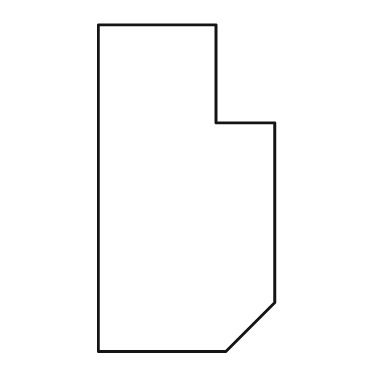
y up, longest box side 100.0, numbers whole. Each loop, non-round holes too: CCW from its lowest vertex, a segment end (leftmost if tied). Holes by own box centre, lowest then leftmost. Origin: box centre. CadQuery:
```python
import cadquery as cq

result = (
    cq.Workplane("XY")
    .moveTo(-27.0, -50.0)
    .lineTo(12.0, -50.0)
    .lineTo(27.0, -35.0)
    .lineTo(27.0, 20.0)
    .lineTo(9.0, 20.0)
    .lineTo(9.0, 50.0)
    .lineTo(-27.0, 50.0)
    .close()
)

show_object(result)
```